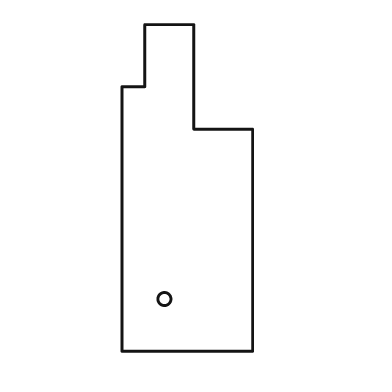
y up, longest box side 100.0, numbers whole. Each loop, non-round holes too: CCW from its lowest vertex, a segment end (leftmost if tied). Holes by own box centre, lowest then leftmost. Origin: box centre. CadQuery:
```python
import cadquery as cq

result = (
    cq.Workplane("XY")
    .moveTo(-20.0, -50.0)
    .lineTo(20.0, -50.0)
    .lineTo(20.0, 18.0)
    .lineTo(2.0, 18.0)
    .lineTo(2.0, 50.0)
    .lineTo(-13.0, 50.0)
    .lineTo(-13.0, 31.0)
    .lineTo(-20.0, 31.0)
    .close()
    .moveTo(-7.0, -34.0)
    .circle(2.0)
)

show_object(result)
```